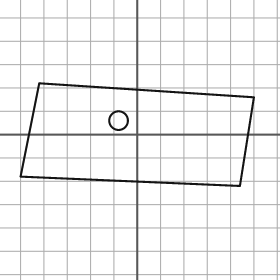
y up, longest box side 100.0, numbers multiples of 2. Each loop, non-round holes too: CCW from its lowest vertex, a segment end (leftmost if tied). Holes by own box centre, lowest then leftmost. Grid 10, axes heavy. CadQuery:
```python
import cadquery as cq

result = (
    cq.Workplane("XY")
    .moveTo(44.0, -22.0)
    .lineTo(50.0, 16.0)
    .lineTo(-42.0, 22.0)
    .lineTo(-50.0, -18.0)
    .close()
    .moveTo(-8.0, 6.0)
    .circle(4.0)
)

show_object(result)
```